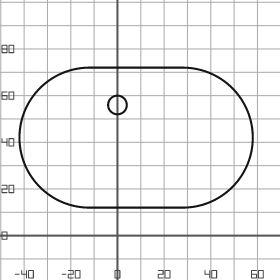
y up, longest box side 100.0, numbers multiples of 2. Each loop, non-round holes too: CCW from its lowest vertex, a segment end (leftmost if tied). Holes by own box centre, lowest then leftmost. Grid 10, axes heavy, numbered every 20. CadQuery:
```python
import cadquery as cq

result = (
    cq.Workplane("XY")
    .moveTo(-12.0, 12.0)
    .lineTo(28.0, 12.0)
    .threePointArc((58.0, 42.0), (28.0, 72.0))
    .lineTo(-12.0, 72.0)
    .threePointArc((-42.0, 42.0), (-12.0, 12.0))
    .close()
    .moveTo(0.0, 56.0)
    .circle(4.0)
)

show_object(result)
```